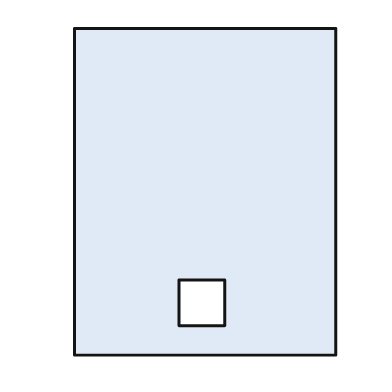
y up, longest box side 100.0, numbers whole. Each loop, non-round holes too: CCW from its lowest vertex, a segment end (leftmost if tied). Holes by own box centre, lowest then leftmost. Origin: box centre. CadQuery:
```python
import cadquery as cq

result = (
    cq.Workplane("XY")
    .moveTo(-40.0, -50.0)
    .lineTo(40.0, -50.0)
    .lineTo(40.0, 50.0)
    .lineTo(-40.0, 50.0)
    .close()
    .moveTo(-8.0, -41.0)
    .lineTo(6.0, -41.0)
    .lineTo(6.0, -27.0)
    .lineTo(-8.0, -27.0)
    .close()
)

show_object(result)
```